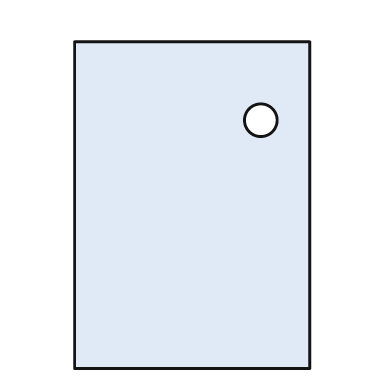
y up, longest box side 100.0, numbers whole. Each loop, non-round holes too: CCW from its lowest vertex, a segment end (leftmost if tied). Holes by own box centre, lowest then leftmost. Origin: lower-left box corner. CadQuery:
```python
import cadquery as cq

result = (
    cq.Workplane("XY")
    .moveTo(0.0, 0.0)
    .lineTo(72.0, 0.0)
    .lineTo(72.0, 100.0)
    .lineTo(0.0, 100.0)
    .close()
    .moveTo(57.0, 76.0)
    .circle(5.0)
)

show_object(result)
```